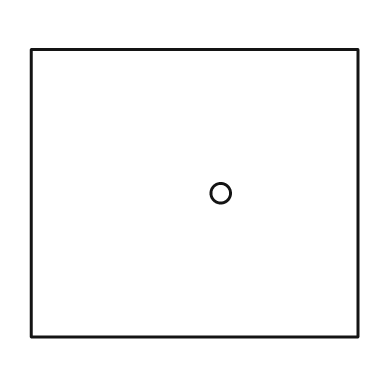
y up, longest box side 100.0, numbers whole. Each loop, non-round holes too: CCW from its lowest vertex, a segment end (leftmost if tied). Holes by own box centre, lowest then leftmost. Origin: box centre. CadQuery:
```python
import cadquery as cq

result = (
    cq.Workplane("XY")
    .moveTo(-50.0, -44.0)
    .lineTo(50.0, -44.0)
    .lineTo(50.0, 44.0)
    .lineTo(-50.0, 44.0)
    .close()
    .moveTo(8.0, 0.0)
    .circle(3.0)
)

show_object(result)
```